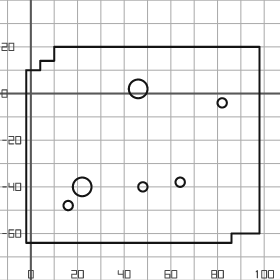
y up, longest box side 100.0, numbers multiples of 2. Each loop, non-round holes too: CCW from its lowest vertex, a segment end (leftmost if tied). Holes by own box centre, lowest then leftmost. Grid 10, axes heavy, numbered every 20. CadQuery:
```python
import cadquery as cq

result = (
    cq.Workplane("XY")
    .moveTo(-2.0, -64.0)
    .lineTo(86.0, -64.0)
    .lineTo(86.0, -60.0)
    .lineTo(98.0, -60.0)
    .lineTo(98.0, 20.0)
    .lineTo(10.0, 20.0)
    .lineTo(10.0, 14.0)
    .lineTo(4.0, 14.0)
    .lineTo(4.0, 10.0)
    .lineTo(-2.0, 10.0)
    .close()
    .moveTo(16.0, -48.0)
    .circle(2.0)
    .moveTo(22.0, -40.0)
    .circle(4.0)
    .moveTo(48.0, -40.0)
    .circle(2.0)
    .moveTo(64.0, -38.0)
    .circle(2.0)
    .moveTo(82.0, -4.0)
    .circle(2.0)
    .moveTo(46.0, 2.0)
    .circle(4.0)
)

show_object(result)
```